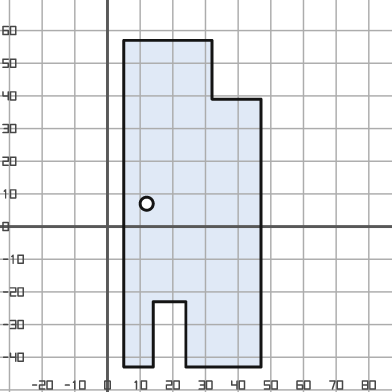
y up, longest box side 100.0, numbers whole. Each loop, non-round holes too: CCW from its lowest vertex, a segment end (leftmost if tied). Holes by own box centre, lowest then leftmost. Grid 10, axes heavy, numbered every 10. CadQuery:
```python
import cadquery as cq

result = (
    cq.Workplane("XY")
    .moveTo(5.0, -43.0)
    .lineTo(14.0, -43.0)
    .lineTo(14.0, -23.0)
    .lineTo(24.0, -23.0)
    .lineTo(24.0, -43.0)
    .lineTo(47.0, -43.0)
    .lineTo(47.0, 39.0)
    .lineTo(32.0, 39.0)
    .lineTo(32.0, 57.0)
    .lineTo(5.0, 57.0)
    .close()
    .moveTo(12.0, 7.0)
    .circle(2.0)
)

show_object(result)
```